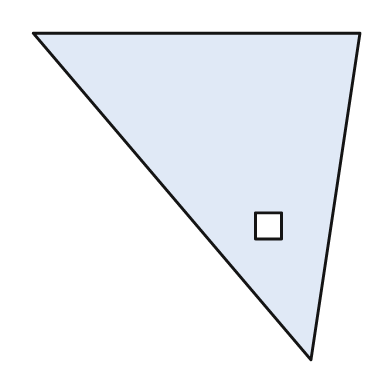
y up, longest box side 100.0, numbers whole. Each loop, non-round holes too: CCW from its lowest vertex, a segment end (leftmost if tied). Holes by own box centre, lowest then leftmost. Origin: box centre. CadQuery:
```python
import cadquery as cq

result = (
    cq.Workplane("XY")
    .moveTo(35.0, -50.0)
    .lineTo(50.0, 50.0)
    .lineTo(-50.0, 50.0)
    .close()
    .moveTo(18.0, -13.0)
    .lineTo(26.0, -13.0)
    .lineTo(26.0, -5.0)
    .lineTo(18.0, -5.0)
    .close()
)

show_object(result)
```